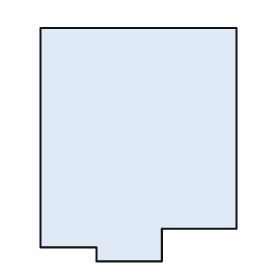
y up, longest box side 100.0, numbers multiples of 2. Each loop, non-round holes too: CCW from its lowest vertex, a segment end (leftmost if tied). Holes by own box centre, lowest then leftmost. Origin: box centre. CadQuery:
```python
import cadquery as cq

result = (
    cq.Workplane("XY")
    .moveTo(-18.0, -50.0)
    .lineTo(10.0, -50.0)
    .lineTo(10.0, -36.0)
    .lineTo(42.0, -36.0)
    .lineTo(42.0, 50.0)
    .lineTo(-42.0, 50.0)
    .lineTo(-42.0, -44.0)
    .lineTo(-18.0, -44.0)
    .close()
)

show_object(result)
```